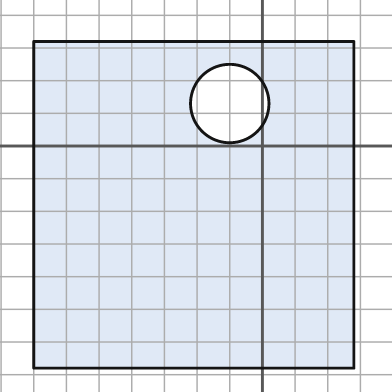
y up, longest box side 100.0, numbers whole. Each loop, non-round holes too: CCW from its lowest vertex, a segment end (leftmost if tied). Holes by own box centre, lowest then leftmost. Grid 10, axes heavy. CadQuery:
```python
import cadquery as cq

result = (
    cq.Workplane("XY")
    .moveTo(-70.0, -68.0)
    .lineTo(28.0, -68.0)
    .lineTo(28.0, 32.0)
    .lineTo(-70.0, 32.0)
    .close()
    .moveTo(-10.0, 13.0)
    .circle(12.0)
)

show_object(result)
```